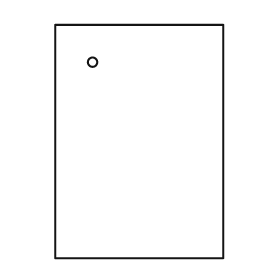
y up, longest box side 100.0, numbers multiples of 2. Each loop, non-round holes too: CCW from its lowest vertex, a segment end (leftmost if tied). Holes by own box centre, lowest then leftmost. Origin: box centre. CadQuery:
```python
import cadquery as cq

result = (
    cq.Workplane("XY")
    .moveTo(-36.0, -50.0)
    .lineTo(36.0, -50.0)
    .lineTo(36.0, 50.0)
    .lineTo(-36.0, 50.0)
    .close()
    .moveTo(-20.0, 34.0)
    .circle(2.0)
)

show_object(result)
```